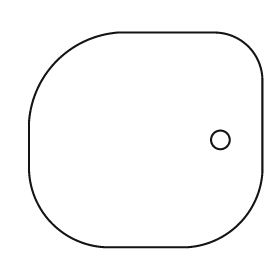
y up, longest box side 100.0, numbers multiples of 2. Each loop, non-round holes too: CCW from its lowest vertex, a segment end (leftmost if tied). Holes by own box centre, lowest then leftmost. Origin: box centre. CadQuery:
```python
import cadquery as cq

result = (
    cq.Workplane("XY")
    .moveTo(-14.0, -46.0)
    .lineTo(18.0, -46.0)
    .threePointArc((40.0, -36.0), (50.0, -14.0))
    .lineTo(50.0, 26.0)
    .threePointArc((44.0, 40.0), (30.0, 46.0))
    .lineTo(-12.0, 46.0)
    .threePointArc((-38.0, 34.0), (-50.0, 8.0))
    .lineTo(-50.0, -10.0)
    .threePointArc((-40.0, -36.0), (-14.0, -46.0))
    .close()
    .moveTo(32.0, 0.0)
    .circle(4.0)
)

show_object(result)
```